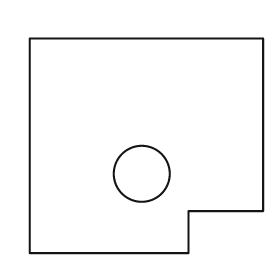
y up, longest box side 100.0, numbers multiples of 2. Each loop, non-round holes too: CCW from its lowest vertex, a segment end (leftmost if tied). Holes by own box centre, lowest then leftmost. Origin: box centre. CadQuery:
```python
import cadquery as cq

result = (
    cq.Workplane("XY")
    .moveTo(-50.0, -46.0)
    .lineTo(18.0, -46.0)
    .lineTo(18.0, -28.0)
    .lineTo(50.0, -28.0)
    .lineTo(50.0, 46.0)
    .lineTo(-50.0, 46.0)
    .close()
    .moveTo(-2.0, -12.0)
    .circle(12.0)
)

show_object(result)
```